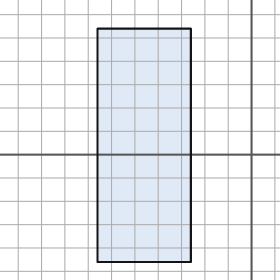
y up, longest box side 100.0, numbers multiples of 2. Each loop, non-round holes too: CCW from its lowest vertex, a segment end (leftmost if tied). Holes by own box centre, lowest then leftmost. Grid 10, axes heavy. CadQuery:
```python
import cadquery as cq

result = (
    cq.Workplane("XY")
    .moveTo(-66.0, -46.0)
    .lineTo(-26.0, -46.0)
    .lineTo(-26.0, 54.0)
    .lineTo(-66.0, 54.0)
    .close()
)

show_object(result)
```